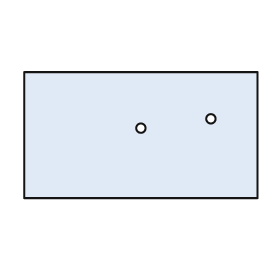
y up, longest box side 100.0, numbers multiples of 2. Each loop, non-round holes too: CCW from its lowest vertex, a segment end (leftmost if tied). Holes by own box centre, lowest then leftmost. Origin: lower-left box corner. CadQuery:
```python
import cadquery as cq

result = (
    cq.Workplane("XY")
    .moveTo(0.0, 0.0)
    .lineTo(100.0, 0.0)
    .lineTo(100.0, 54.0)
    .lineTo(0.0, 54.0)
    .close()
    .moveTo(50.0, 30.0)
    .circle(2.0)
    .moveTo(80.0, 34.0)
    .circle(2.0)
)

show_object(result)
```